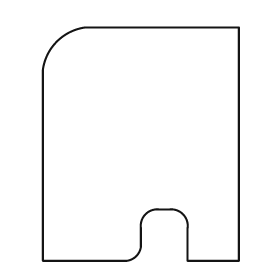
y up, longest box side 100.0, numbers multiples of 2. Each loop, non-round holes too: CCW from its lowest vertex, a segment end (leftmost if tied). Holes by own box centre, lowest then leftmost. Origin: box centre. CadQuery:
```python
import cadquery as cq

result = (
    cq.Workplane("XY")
    .moveTo(-42.0, -50.0)
    .lineTo(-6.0, -50.0)
    .threePointArc((-2.0, -48.0), (0.0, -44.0))
    .lineTo(0.0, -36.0)
    .threePointArc((2.0, -30.0), (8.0, -28.0))
    .lineTo(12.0, -28.0)
    .threePointArc((18.0, -30.0), (20.0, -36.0))
    .lineTo(20.0, -50.0)
    .lineTo(42.0, -50.0)
    .lineTo(42.0, 50.0)
    .lineTo(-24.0, 50.0)
    .threePointArc((-36.0, 44.0), (-42.0, 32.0))
    .close()
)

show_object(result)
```